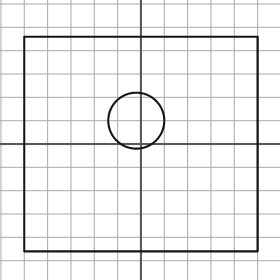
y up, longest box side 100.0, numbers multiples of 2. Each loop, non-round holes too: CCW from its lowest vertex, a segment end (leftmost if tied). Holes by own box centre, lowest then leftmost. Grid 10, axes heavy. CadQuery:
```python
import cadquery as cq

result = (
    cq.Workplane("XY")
    .moveTo(-50.0, -46.0)
    .lineTo(50.0, -46.0)
    .lineTo(50.0, 46.0)
    .lineTo(-50.0, 46.0)
    .close()
    .moveTo(-2.0, 10.0)
    .circle(12.0)
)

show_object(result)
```